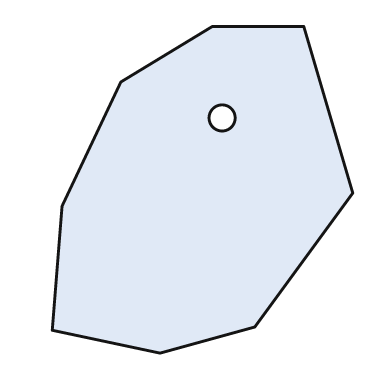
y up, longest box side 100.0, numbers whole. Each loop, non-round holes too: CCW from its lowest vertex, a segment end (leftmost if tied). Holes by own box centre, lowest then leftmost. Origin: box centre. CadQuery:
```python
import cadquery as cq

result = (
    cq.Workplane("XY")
    .moveTo(-13.0, -50.0)
    .lineTo(16.0, -42.0)
    .lineTo(46.0, -1.0)
    .lineTo(31.0, 50.0)
    .lineTo(3.0, 50.0)
    .lineTo(-25.0, 33.0)
    .lineTo(-43.0, -5.0)
    .lineTo(-46.0, -43.0)
    .close()
    .moveTo(6.0, 22.0)
    .circle(4.0)
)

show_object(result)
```